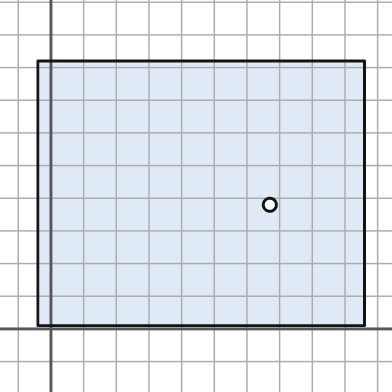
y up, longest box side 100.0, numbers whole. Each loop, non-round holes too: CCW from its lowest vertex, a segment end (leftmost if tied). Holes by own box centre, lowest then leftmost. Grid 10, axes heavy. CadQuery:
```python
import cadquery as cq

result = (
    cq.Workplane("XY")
    .moveTo(-4.0, 1.0)
    .lineTo(96.0, 1.0)
    .lineTo(96.0, 82.0)
    .lineTo(-4.0, 82.0)
    .close()
    .moveTo(67.0, 38.0)
    .circle(2.0)
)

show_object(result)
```